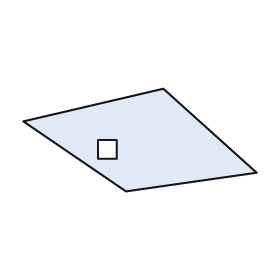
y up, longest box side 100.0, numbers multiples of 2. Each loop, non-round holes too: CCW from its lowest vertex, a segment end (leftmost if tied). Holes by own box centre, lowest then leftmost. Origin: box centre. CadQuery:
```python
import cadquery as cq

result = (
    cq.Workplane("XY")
    .moveTo(-6.0, -22.0)
    .lineTo(50.0, -14.0)
    .lineTo(10.0, 22.0)
    .lineTo(-50.0, 8.0)
    .close()
    .moveTo(-18.0, -8.0)
    .lineTo(-10.0, -8.0)
    .lineTo(-10.0, 0.0)
    .lineTo(-18.0, 0.0)
    .close()
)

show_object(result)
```